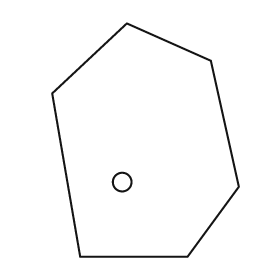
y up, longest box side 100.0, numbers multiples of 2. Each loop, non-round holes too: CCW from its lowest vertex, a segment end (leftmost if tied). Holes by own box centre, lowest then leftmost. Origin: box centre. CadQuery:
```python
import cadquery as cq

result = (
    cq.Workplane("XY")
    .moveTo(-28.0, -50.0)
    .lineTo(18.0, -50.0)
    .lineTo(40.0, -20.0)
    .lineTo(28.0, 34.0)
    .lineTo(-8.0, 50.0)
    .lineTo(-40.0, 20.0)
    .close()
    .moveTo(-10.0, -18.0)
    .circle(4.0)
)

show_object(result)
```